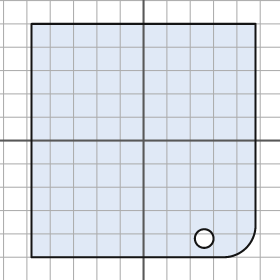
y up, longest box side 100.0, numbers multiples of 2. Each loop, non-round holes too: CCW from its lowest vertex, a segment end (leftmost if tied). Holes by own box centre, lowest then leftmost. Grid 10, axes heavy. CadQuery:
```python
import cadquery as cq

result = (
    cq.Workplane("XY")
    .moveTo(-48.0, -50.0)
    .lineTo(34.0, -50.0)
    .threePointArc((44.0, -46.0), (48.0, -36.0))
    .lineTo(48.0, 50.0)
    .lineTo(-48.0, 50.0)
    .close()
    .moveTo(26.0, -42.0)
    .circle(4.0)
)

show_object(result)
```